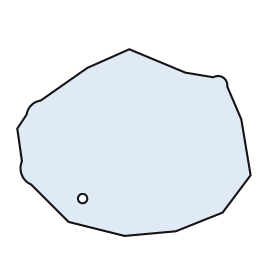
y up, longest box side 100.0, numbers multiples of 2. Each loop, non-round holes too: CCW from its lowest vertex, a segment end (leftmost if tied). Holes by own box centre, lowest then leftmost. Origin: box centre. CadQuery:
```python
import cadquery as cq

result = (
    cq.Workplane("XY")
    .moveTo(-4.0, -40.0)
    .lineTo(18.0, -38.0)
    .lineTo(38.0, -30.0)
    .lineTo(50.0, -14.0)
    .lineTo(46.0, 10.0)
    .lineTo(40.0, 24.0)
    .threePointArc((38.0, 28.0), (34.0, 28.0))
    .lineTo(22.0, 30.0)
    .lineTo(-2.0, 40.0)
    .lineTo(-20.0, 32.0)
    .lineTo(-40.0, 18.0)
    .threePointArc((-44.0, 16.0), (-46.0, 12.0))
    .lineTo(-50.0, 6.0)
    .lineTo(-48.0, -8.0)
    .threePointArc((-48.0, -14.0), (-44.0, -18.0))
    .lineTo(-28.0, -34.0)
    .close()
    .moveTo(-22.0, -24.0)
    .circle(2.0)
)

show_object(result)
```